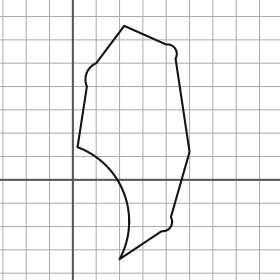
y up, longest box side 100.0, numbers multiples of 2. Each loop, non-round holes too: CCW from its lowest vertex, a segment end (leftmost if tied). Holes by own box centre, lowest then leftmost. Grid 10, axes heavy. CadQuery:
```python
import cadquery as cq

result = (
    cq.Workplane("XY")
    .moveTo(20.0, -34.0)
    .lineTo(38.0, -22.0)
    .threePointArc((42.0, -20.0), (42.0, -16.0))
    .lineTo(50.0, 12.0)
    .lineTo(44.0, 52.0)
    .threePointArc((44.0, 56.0), (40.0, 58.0))
    .lineTo(22.0, 66.0)
    .lineTo(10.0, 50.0)
    .threePointArc((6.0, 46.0), (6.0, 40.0))
    .lineTo(2.0, 14.0)
    .threePointArc((22.0, -6.0), (20.0, -34.0))
    .close()
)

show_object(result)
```